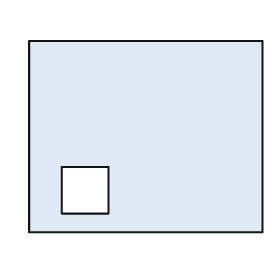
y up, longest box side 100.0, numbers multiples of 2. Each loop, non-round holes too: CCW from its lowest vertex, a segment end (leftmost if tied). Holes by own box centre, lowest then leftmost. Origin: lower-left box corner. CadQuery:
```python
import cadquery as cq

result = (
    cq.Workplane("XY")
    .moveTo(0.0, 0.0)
    .lineTo(100.0, 0.0)
    .lineTo(100.0, 82.0)
    .lineTo(0.0, 82.0)
    .close()
    .moveTo(14.0, 8.0)
    .lineTo(34.0, 8.0)
    .lineTo(34.0, 28.0)
    .lineTo(14.0, 28.0)
    .close()
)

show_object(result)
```